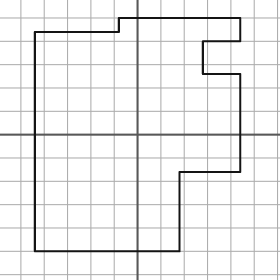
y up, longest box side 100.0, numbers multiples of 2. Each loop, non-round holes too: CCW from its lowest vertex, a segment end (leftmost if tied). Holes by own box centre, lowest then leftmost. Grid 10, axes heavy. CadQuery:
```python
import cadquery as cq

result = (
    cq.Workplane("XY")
    .moveTo(-44.0, -50.0)
    .lineTo(18.0, -50.0)
    .lineTo(18.0, -16.0)
    .lineTo(44.0, -16.0)
    .lineTo(44.0, 26.0)
    .lineTo(28.0, 26.0)
    .lineTo(28.0, 40.0)
    .lineTo(44.0, 40.0)
    .lineTo(44.0, 50.0)
    .lineTo(-8.0, 50.0)
    .lineTo(-8.0, 44.0)
    .lineTo(-44.0, 44.0)
    .close()
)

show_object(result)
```